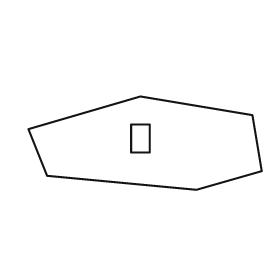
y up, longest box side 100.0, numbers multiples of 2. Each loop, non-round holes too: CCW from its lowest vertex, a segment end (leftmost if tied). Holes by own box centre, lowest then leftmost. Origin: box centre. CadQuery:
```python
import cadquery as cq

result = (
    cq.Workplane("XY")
    .moveTo(22.0, -20.0)
    .lineTo(50.0, -12.0)
    .lineTo(46.0, 12.0)
    .lineTo(-2.0, 20.0)
    .lineTo(-50.0, 6.0)
    .lineTo(-42.0, -14.0)
    .close()
    .moveTo(-6.0, -4.0)
    .lineTo(2.0, -4.0)
    .lineTo(2.0, 8.0)
    .lineTo(-6.0, 8.0)
    .close()
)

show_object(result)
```